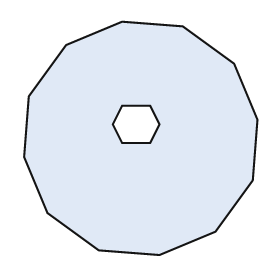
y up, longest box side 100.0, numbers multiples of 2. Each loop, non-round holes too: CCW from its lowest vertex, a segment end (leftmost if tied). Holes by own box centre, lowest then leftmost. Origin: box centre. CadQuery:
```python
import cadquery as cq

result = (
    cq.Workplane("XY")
    .moveTo(8.0, -50.0)
    .lineTo(32.0, -40.0)
    .lineTo(48.0, -18.0)
    .lineTo(50.0, 8.0)
    .lineTo(40.0, 32.0)
    .lineTo(18.0, 48.0)
    .lineTo(-8.0, 50.0)
    .lineTo(-32.0, 40.0)
    .lineTo(-48.0, 18.0)
    .lineTo(-50.0, -8.0)
    .lineTo(-40.0, -32.0)
    .lineTo(-18.0, -48.0)
    .close()
    .moveTo(-8.0, -2.0)
    .lineTo(4.0, -2.0)
    .lineTo(8.0, 6.0)
    .lineTo(4.0, 14.0)
    .lineTo(-8.0, 14.0)
    .lineTo(-12.0, 6.0)
    .close()
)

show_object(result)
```